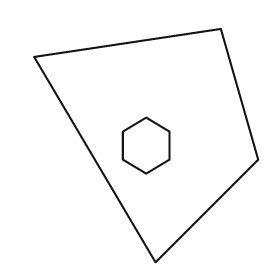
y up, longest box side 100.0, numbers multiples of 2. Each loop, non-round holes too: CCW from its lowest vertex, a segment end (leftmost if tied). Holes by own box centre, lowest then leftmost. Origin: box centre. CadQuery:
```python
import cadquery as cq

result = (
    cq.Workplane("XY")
    .moveTo(4.0, -50.0)
    .lineTo(48.0, -6.0)
    .lineTo(32.0, 50.0)
    .lineTo(-48.0, 38.0)
    .close()
    .moveTo(0.0, -12.0)
    .lineTo(10.0, -6.0)
    .lineTo(10.0, 6.0)
    .lineTo(0.0, 12.0)
    .lineTo(-10.0, 6.0)
    .lineTo(-10.0, -6.0)
    .close()
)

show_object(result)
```